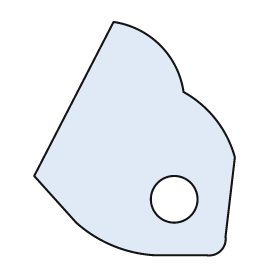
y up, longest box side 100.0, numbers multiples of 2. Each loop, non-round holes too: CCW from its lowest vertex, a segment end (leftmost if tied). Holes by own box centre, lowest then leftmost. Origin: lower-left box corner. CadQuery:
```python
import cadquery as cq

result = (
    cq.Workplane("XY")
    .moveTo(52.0, 0.0)
    .lineTo(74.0, 0.0)
    .threePointArc((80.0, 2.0), (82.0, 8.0))
    .lineTo(86.0, 42.0)
    .threePointArc((78.0, 58.0), (64.0, 70.0))
    .threePointArc((54.0, 90.0), (34.0, 100.0))
    .lineTo(0.0, 34.0)
    .lineTo(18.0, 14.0)
    .threePointArc((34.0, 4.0), (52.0, 0.0))
    .close()
    .moveTo(60.0, 24.0)
    .circle(10.0)
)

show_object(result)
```